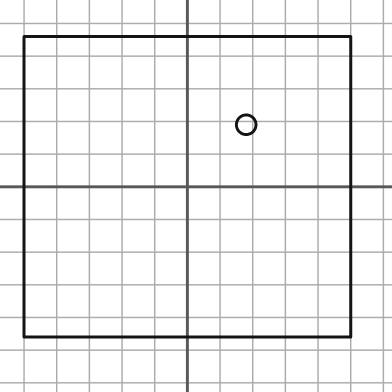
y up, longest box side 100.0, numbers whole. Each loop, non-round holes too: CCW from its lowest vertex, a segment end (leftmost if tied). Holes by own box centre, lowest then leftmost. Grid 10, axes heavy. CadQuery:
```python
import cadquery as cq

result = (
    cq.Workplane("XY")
    .moveTo(-50.0, -46.0)
    .lineTo(50.0, -46.0)
    .lineTo(50.0, 46.0)
    .lineTo(-50.0, 46.0)
    .close()
    .moveTo(18.0, 19.0)
    .circle(3.0)
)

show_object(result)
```